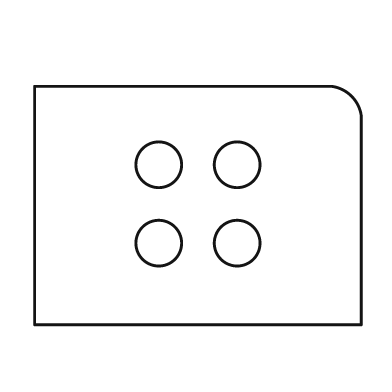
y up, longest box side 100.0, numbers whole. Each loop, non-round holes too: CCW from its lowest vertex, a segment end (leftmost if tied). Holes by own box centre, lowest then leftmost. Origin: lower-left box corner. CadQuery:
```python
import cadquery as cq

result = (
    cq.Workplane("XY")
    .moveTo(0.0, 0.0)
    .lineTo(100.0, 0.0)
    .lineTo(100.0, 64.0)
    .threePointArc((97.0, 70.0), (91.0, 73.0))
    .lineTo(0.0, 73.0)
    .close()
    .moveTo(38.0, 25.0)
    .circle(7.0)
    .moveTo(62.0, 25.0)
    .circle(7.0)
    .moveTo(38.0, 49.0)
    .circle(7.0)
    .moveTo(62.0, 49.0)
    .circle(7.0)
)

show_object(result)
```